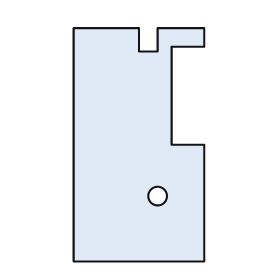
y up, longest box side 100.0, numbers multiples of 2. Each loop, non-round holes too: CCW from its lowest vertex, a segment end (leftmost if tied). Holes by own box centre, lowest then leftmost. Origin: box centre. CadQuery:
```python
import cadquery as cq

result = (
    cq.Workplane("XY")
    .moveTo(-28.0, -50.0)
    .lineTo(28.0, -50.0)
    .lineTo(28.0, 0.0)
    .lineTo(14.0, 0.0)
    .lineTo(14.0, 42.0)
    .lineTo(28.0, 42.0)
    .lineTo(28.0, 50.0)
    .lineTo(8.0, 50.0)
    .lineTo(8.0, 40.0)
    .lineTo(0.0, 40.0)
    .lineTo(0.0, 50.0)
    .lineTo(-28.0, 50.0)
    .close()
    .moveTo(8.0, -22.0)
    .circle(4.0)
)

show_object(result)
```